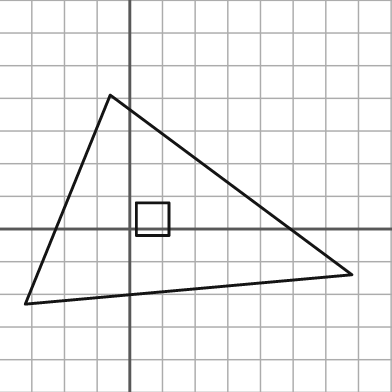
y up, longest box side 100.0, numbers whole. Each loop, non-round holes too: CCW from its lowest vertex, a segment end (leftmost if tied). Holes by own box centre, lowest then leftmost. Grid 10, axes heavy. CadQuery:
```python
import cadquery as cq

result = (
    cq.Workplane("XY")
    .moveTo(-32.0, -23.0)
    .lineTo(68.0, -14.0)
    .lineTo(-6.0, 41.0)
    .close()
    .moveTo(2.0, -2.0)
    .lineTo(12.0, -2.0)
    .lineTo(12.0, 8.0)
    .lineTo(2.0, 8.0)
    .close()
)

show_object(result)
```